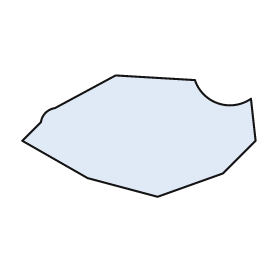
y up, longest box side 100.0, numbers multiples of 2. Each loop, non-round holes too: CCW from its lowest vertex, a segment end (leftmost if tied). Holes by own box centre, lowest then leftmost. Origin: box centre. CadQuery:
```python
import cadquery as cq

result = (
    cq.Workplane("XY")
    .moveTo(8.0, -26.0)
    .lineTo(36.0, -16.0)
    .lineTo(50.0, -2.0)
    .lineTo(48.0, 16.0)
    .threePointArc((34.0, 14.0), (24.0, 24.0))
    .lineTo(-10.0, 26.0)
    .lineTo(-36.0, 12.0)
    .threePointArc((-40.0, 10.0), (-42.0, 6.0))
    .lineTo(-50.0, -2.0)
    .lineTo(-22.0, -18.0)
    .close()
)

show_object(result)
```